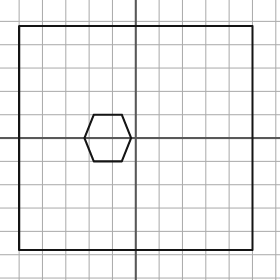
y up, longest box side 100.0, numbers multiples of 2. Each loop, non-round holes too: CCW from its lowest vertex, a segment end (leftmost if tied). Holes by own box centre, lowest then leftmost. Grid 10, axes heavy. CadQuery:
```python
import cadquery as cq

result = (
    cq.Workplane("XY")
    .moveTo(-50.0, -48.0)
    .lineTo(50.0, -48.0)
    .lineTo(50.0, 48.0)
    .lineTo(-50.0, 48.0)
    .close()
    .moveTo(-18.0, -10.0)
    .lineTo(-6.0, -10.0)
    .lineTo(-2.0, 0.0)
    .lineTo(-6.0, 10.0)
    .lineTo(-18.0, 10.0)
    .lineTo(-22.0, 0.0)
    .close()
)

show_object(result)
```